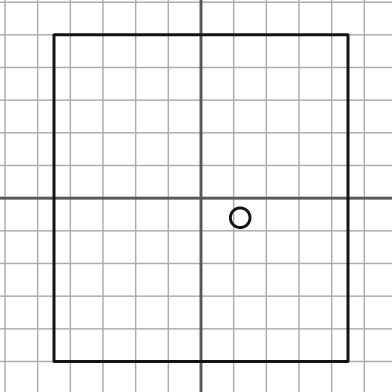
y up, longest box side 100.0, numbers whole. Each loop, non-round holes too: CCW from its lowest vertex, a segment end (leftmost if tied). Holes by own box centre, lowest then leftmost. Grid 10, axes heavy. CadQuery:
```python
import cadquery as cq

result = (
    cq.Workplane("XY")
    .moveTo(-45.0, -50.0)
    .lineTo(45.0, -50.0)
    .lineTo(45.0, 50.0)
    .lineTo(-45.0, 50.0)
    .close()
    .moveTo(12.0, -6.0)
    .circle(3.0)
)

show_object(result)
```